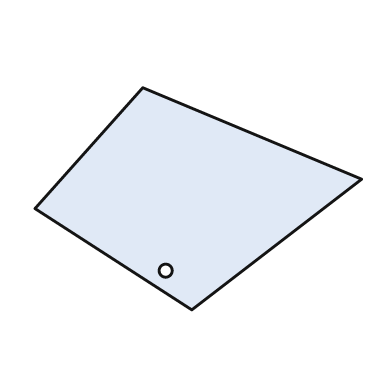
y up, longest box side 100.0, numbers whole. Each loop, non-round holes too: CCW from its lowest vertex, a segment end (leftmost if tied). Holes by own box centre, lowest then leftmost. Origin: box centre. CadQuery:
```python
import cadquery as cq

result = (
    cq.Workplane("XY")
    .moveTo(-2.0, -34.0)
    .lineTo(50.0, 6.0)
    .lineTo(-17.0, 34.0)
    .lineTo(-50.0, -3.0)
    .close()
    .moveTo(-10.0, -22.0)
    .circle(2.0)
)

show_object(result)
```